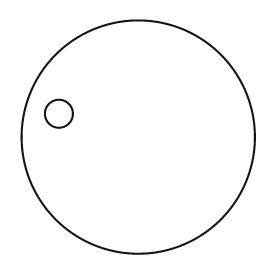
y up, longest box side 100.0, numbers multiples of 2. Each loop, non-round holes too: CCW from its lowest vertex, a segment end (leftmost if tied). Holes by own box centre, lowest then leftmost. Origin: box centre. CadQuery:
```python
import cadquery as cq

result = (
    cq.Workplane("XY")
    .moveTo(0.0, 0.0)
    .circle(50.0)
    .moveTo(-34.0, 10.0)
    .circle(6.0)
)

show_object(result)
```